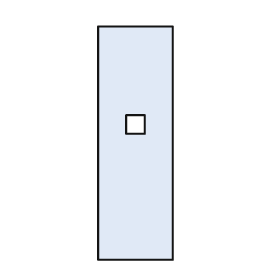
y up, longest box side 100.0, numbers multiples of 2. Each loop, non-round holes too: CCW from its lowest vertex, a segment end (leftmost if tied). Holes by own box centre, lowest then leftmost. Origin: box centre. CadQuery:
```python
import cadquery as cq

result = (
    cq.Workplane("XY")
    .moveTo(-16.0, -50.0)
    .lineTo(16.0, -50.0)
    .lineTo(16.0, 50.0)
    .lineTo(-16.0, 50.0)
    .close()
    .moveTo(-4.0, 4.0)
    .lineTo(4.0, 4.0)
    .lineTo(4.0, 12.0)
    .lineTo(-4.0, 12.0)
    .close()
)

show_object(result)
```